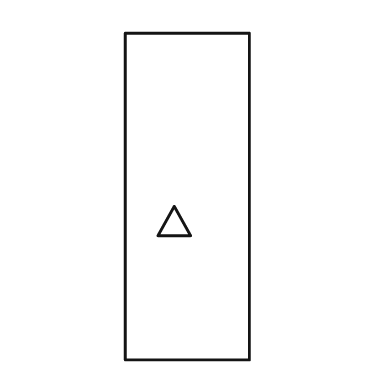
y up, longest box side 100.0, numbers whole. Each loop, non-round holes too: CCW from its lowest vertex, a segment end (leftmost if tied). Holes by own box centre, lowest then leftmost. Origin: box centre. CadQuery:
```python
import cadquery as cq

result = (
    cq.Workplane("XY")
    .moveTo(-19.0, -50.0)
    .lineTo(19.0, -50.0)
    .lineTo(19.0, 50.0)
    .lineTo(-19.0, 50.0)
    .close()
    .moveTo(-9.0, -12.0)
    .lineTo(1.0, -12.0)
    .lineTo(-4.0, -3.0)
    .close()
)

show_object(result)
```